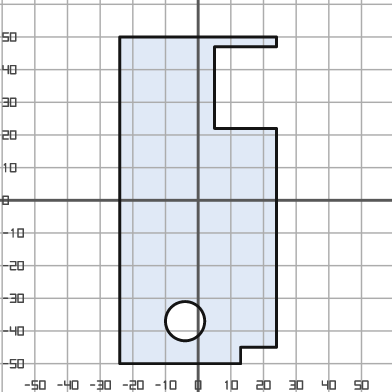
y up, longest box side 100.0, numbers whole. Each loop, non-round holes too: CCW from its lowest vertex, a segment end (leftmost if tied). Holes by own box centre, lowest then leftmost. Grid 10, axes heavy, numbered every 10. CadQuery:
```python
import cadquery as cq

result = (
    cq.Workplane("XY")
    .moveTo(-24.0, -50.0)
    .lineTo(13.0, -50.0)
    .lineTo(13.0, -45.0)
    .lineTo(24.0, -45.0)
    .lineTo(24.0, 22.0)
    .lineTo(5.0, 22.0)
    .lineTo(5.0, 47.0)
    .lineTo(24.0, 47.0)
    .lineTo(24.0, 50.0)
    .lineTo(-24.0, 50.0)
    .close()
    .moveTo(-4.0, -37.0)
    .circle(6.0)
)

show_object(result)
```